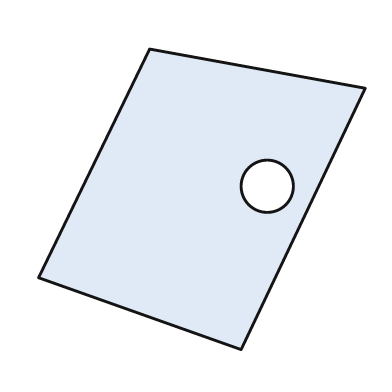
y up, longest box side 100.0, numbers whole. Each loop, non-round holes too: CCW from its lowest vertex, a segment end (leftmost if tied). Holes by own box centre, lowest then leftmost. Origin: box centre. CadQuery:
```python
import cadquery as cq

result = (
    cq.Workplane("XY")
    .moveTo(12.0, -46.0)
    .lineTo(50.0, 34.0)
    .lineTo(-16.0, 46.0)
    .lineTo(-50.0, -24.0)
    .close()
    .moveTo(20.0, 4.0)
    .circle(8.0)
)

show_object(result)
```